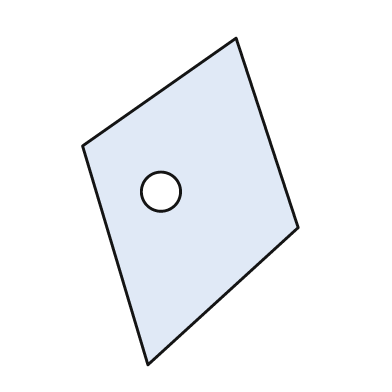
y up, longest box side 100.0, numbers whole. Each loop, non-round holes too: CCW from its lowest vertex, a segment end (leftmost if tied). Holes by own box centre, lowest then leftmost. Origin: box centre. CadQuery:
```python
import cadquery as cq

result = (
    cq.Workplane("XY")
    .moveTo(-13.0, -50.0)
    .lineTo(33.0, -8.0)
    .lineTo(14.0, 50.0)
    .lineTo(-33.0, 17.0)
    .close()
    .moveTo(-9.0, 3.0)
    .circle(6.0)
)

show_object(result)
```